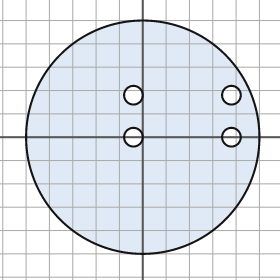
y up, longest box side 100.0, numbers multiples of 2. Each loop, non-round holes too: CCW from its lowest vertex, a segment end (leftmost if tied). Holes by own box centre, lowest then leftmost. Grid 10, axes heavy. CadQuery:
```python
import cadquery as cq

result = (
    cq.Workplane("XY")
    .moveTo(0.0, 0.0)
    .circle(50.0)
    .moveTo(-4.0, 0.0)
    .circle(4.0)
    .moveTo(38.0, 0.0)
    .circle(4.0)
    .moveTo(-4.0, 18.0)
    .circle(4.0)
    .moveTo(38.0, 18.0)
    .circle(4.0)
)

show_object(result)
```